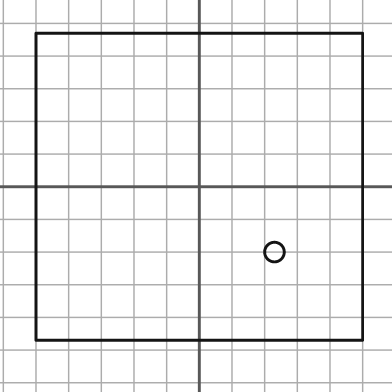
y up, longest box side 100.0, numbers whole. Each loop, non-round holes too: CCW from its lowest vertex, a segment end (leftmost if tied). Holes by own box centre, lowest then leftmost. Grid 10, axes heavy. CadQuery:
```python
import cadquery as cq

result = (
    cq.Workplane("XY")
    .moveTo(-50.0, -47.0)
    .lineTo(50.0, -47.0)
    .lineTo(50.0, 47.0)
    .lineTo(-50.0, 47.0)
    .close()
    .moveTo(23.0, -20.0)
    .circle(3.0)
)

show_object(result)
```